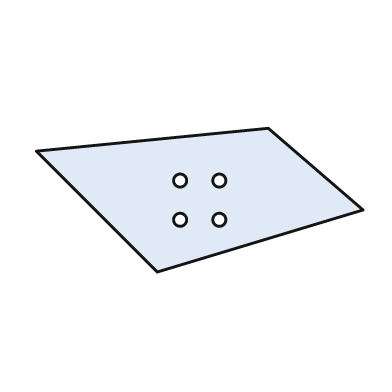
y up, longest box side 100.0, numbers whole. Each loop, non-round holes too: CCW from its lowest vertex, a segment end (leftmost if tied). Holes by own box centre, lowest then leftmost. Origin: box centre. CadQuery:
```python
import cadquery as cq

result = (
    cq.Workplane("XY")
    .moveTo(-13.0, -22.0)
    .lineTo(50.0, -3.0)
    .lineTo(21.0, 22.0)
    .lineTo(-50.0, 15.0)
    .close()
    .moveTo(-6.0, -6.0)
    .circle(2.0)
    .moveTo(6.0, -6.0)
    .circle(2.0)
    .moveTo(-6.0, 6.0)
    .circle(2.0)
    .moveTo(6.0, 6.0)
    .circle(2.0)
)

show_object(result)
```